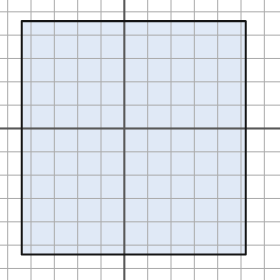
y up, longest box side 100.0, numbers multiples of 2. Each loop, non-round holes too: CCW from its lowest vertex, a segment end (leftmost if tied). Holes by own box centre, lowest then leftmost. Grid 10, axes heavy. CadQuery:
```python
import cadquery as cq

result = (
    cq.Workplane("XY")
    .moveTo(-44.0, -54.0)
    .lineTo(52.0, -54.0)
    .lineTo(52.0, 46.0)
    .lineTo(-44.0, 46.0)
    .close()
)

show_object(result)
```